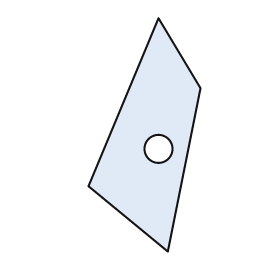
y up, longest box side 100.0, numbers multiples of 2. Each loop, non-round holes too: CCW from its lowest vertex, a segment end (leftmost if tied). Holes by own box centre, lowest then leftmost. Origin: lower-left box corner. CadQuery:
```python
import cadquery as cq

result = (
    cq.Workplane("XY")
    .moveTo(34.0, 0.0)
    .lineTo(48.0, 70.0)
    .lineTo(30.0, 100.0)
    .lineTo(0.0, 28.0)
    .close()
    .moveTo(30.0, 44.0)
    .circle(6.0)
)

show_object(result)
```